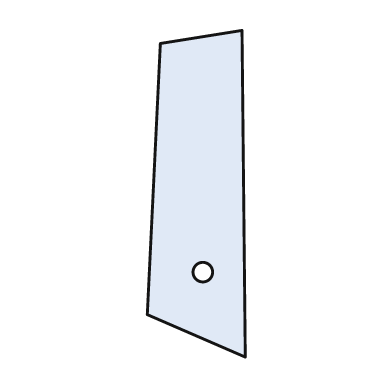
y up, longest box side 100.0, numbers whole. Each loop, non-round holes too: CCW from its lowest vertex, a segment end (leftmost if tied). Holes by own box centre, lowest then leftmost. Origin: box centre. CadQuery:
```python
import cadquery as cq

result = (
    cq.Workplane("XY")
    .moveTo(15.0, -50.0)
    .lineTo(14.0, 50.0)
    .lineTo(-11.0, 46.0)
    .lineTo(-15.0, -37.0)
    .close()
    .moveTo(2.0, -24.0)
    .circle(3.0)
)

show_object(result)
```